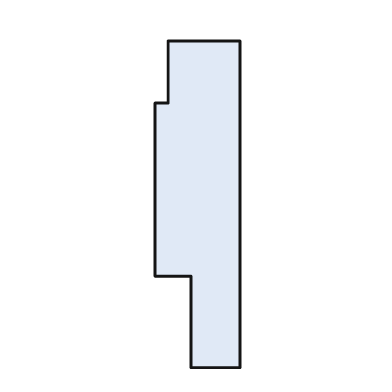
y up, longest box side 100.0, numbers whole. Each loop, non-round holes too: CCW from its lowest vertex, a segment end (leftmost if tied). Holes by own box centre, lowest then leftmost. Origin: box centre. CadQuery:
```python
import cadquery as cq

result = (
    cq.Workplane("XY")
    .moveTo(-2.0, -50.0)
    .lineTo(13.0, -50.0)
    .lineTo(13.0, 50.0)
    .lineTo(-9.0, 50.0)
    .lineTo(-9.0, 31.0)
    .lineTo(-13.0, 31.0)
    .lineTo(-13.0, -22.0)
    .lineTo(-2.0, -22.0)
    .close()
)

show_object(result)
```